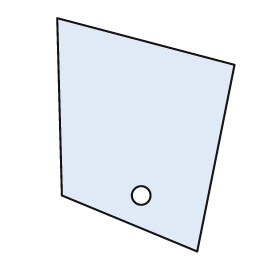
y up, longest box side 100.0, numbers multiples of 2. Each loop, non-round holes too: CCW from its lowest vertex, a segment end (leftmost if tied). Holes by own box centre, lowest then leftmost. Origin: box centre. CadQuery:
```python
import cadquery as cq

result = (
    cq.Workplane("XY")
    .moveTo(22.0, -50.0)
    .lineTo(38.0, 30.0)
    .lineTo(-38.0, 50.0)
    .lineTo(-36.0, -26.0)
    .close()
    .moveTo(-2.0, -26.0)
    .circle(4.0)
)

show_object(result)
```